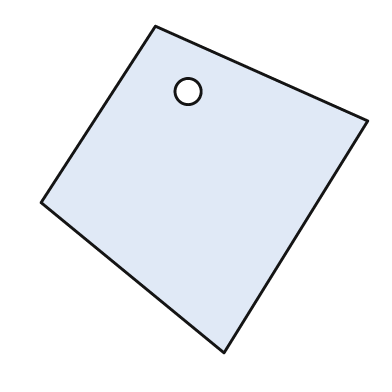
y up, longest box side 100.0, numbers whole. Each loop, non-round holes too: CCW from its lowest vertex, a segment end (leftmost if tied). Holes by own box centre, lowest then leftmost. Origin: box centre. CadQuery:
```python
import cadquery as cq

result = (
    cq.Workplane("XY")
    .moveTo(6.0, -50.0)
    .lineTo(50.0, 21.0)
    .lineTo(-15.0, 50.0)
    .lineTo(-50.0, -4.0)
    .close()
    .moveTo(-5.0, 30.0)
    .circle(4.0)
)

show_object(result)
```